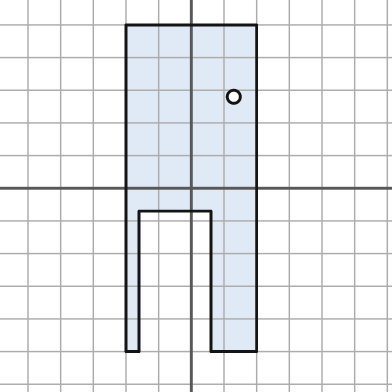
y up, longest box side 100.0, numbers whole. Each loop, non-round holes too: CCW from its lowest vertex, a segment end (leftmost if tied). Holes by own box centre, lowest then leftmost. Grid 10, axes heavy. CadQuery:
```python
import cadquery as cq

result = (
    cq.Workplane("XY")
    .moveTo(-20.0, -50.0)
    .lineTo(-16.0, -50.0)
    .lineTo(-16.0, -7.0)
    .lineTo(6.0, -7.0)
    .lineTo(6.0, -50.0)
    .lineTo(20.0, -50.0)
    .lineTo(20.0, 50.0)
    .lineTo(-20.0, 50.0)
    .close()
    .moveTo(13.0, 28.0)
    .circle(2.0)
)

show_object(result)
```